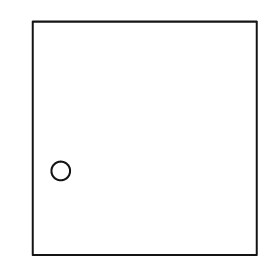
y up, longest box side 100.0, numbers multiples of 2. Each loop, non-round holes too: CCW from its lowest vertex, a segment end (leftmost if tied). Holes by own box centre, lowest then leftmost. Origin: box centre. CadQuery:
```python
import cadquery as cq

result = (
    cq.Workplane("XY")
    .moveTo(-48.0, -50.0)
    .lineTo(48.0, -50.0)
    .lineTo(48.0, 50.0)
    .lineTo(-48.0, 50.0)
    .close()
    .moveTo(-36.0, -14.0)
    .circle(4.0)
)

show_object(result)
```